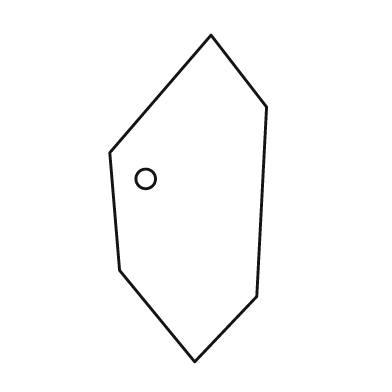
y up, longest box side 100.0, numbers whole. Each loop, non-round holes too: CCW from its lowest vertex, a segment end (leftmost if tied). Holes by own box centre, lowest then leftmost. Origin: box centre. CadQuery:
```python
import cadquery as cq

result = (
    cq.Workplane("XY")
    .moveTo(2.0, -50.0)
    .lineTo(21.0, -30.0)
    .lineTo(24.0, 28.0)
    .lineTo(7.0, 50.0)
    .lineTo(-24.0, 14.0)
    .lineTo(-21.0, -22.0)
    .close()
    .moveTo(-13.0, 6.0)
    .circle(3.0)
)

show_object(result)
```